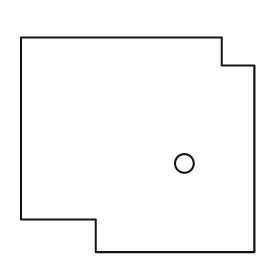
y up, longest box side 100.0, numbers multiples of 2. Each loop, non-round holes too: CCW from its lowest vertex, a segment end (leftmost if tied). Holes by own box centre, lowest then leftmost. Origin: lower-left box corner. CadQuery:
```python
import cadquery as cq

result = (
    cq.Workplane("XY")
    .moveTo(32.0, 0.0)
    .lineTo(100.0, 0.0)
    .lineTo(100.0, 80.0)
    .lineTo(86.0, 80.0)
    .lineTo(86.0, 92.0)
    .lineTo(0.0, 92.0)
    .lineTo(0.0, 14.0)
    .lineTo(32.0, 14.0)
    .close()
    .moveTo(70.0, 38.0)
    .circle(4.0)
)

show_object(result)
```